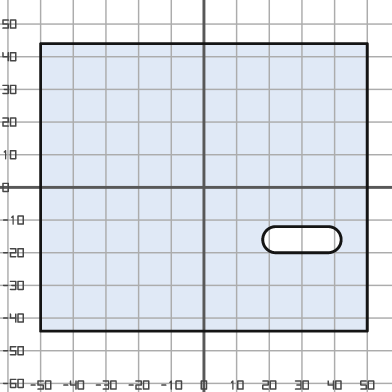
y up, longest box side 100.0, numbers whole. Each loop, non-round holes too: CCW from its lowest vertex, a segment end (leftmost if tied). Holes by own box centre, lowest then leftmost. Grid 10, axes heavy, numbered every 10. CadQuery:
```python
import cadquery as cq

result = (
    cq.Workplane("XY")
    .moveTo(-50.0, -44.0)
    .lineTo(50.0, -44.0)
    .lineTo(50.0, 44.0)
    .lineTo(-50.0, 44.0)
    .close()
    .moveTo(22.0, -20.0)
    .lineTo(38.0, -20.0)
    .threePointArc((42.0, -16.0), (38.0, -12.0))
    .lineTo(22.0, -12.0)
    .threePointArc((18.0, -16.0), (22.0, -20.0))
    .close()
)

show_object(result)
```